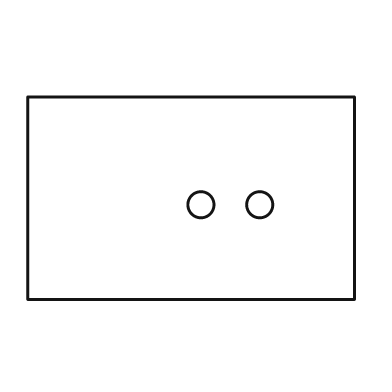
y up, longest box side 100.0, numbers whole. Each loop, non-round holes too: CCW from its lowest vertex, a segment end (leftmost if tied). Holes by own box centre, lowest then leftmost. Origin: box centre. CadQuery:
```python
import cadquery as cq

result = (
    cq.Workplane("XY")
    .moveTo(-50.0, -31.0)
    .lineTo(50.0, -31.0)
    .lineTo(50.0, 31.0)
    .lineTo(-50.0, 31.0)
    .close()
    .moveTo(3.0, -2.0)
    .circle(4.0)
    .moveTo(21.0, -2.0)
    .circle(4.0)
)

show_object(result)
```